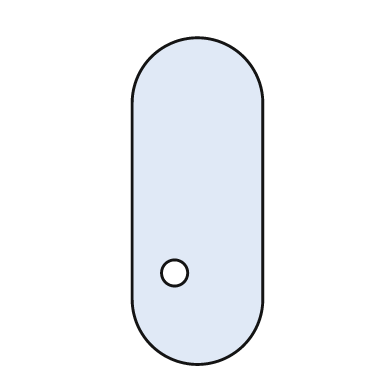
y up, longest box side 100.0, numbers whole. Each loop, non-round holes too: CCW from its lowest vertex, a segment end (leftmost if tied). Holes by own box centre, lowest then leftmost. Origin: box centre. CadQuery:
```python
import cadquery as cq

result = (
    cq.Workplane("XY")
    .moveTo(-20.0, -30.0)
    .threePointArc((0.0, -50.0), (20.0, -30.0))
    .lineTo(20.0, 30.0)
    .threePointArc((0.0, 50.0), (-20.0, 30.0))
    .close()
    .moveTo(-7.0, -22.0)
    .circle(4.0)
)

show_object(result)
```